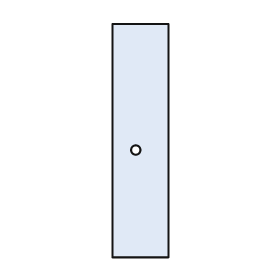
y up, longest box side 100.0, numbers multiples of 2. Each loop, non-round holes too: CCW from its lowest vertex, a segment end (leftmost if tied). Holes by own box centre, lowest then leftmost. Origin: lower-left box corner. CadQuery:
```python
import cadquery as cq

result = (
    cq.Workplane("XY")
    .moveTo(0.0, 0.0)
    .lineTo(24.0, 0.0)
    .lineTo(24.0, 100.0)
    .lineTo(0.0, 100.0)
    .close()
    .moveTo(10.0, 46.0)
    .circle(2.0)
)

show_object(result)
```